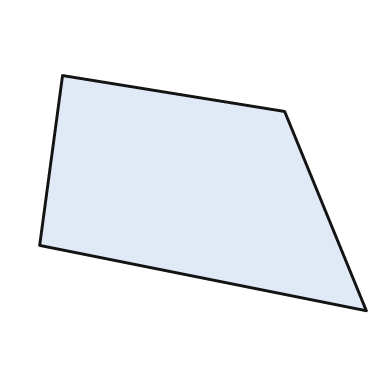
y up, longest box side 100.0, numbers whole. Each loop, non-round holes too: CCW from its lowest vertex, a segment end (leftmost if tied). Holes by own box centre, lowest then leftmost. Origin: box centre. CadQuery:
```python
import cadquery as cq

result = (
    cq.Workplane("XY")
    .moveTo(50.0, -36.0)
    .lineTo(25.0, 25.0)
    .lineTo(-43.0, 36.0)
    .lineTo(-50.0, -16.0)
    .close()
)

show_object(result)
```